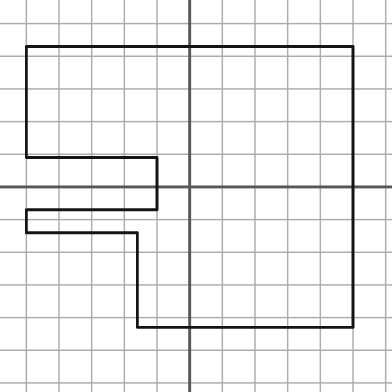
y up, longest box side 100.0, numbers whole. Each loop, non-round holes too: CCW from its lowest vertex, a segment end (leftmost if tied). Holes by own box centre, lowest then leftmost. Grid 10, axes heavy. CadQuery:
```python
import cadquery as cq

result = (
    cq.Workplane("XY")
    .moveTo(-16.0, -43.0)
    .lineTo(50.0, -43.0)
    .lineTo(50.0, 43.0)
    .lineTo(-50.0, 43.0)
    .lineTo(-50.0, 9.0)
    .lineTo(-10.0, 9.0)
    .lineTo(-10.0, -7.0)
    .lineTo(-50.0, -7.0)
    .lineTo(-50.0, -14.0)
    .lineTo(-16.0, -14.0)
    .close()
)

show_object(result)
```